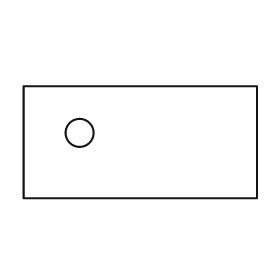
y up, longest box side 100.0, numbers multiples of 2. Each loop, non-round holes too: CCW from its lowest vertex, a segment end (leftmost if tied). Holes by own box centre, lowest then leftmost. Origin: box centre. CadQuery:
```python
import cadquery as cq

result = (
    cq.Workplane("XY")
    .moveTo(-50.0, -24.0)
    .lineTo(50.0, -24.0)
    .lineTo(50.0, 24.0)
    .lineTo(-50.0, 24.0)
    .close()
    .moveTo(-26.0, 4.0)
    .circle(6.0)
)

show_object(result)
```